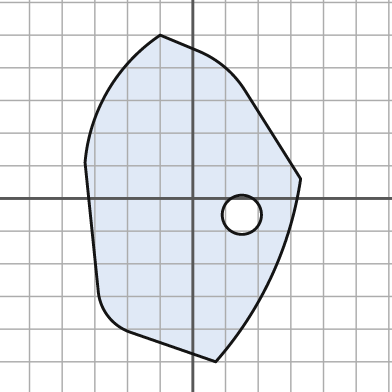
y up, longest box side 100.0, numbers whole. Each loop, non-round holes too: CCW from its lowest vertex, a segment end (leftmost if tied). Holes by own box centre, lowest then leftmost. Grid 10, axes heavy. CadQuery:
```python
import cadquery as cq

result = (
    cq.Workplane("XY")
    .moveTo(7.0, -50.0)
    .threePointArc((24.0, -24.0), (33.0, 6.0))
    .lineTo(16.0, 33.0)
    .threePointArc((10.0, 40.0), (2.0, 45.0))
    .lineTo(-10.0, 50.0)
    .threePointArc((-26.0, 33.0), (-33.0, 11.0))
    .lineTo(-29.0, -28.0)
    .threePointArc((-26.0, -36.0), (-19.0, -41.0))
    .close()
    .moveTo(15.0, -5.0)
    .circle(6.0)
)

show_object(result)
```